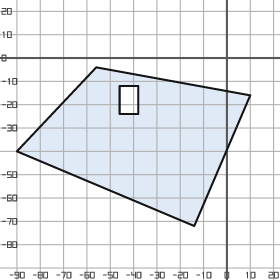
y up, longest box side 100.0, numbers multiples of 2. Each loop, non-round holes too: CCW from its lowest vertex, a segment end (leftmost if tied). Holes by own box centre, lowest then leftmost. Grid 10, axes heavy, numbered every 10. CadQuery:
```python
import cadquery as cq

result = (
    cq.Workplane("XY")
    .moveTo(-14.0, -72.0)
    .lineTo(10.0, -16.0)
    .lineTo(-56.0, -4.0)
    .lineTo(-90.0, -40.0)
    .close()
    .moveTo(-46.0, -24.0)
    .lineTo(-38.0, -24.0)
    .lineTo(-38.0, -12.0)
    .lineTo(-46.0, -12.0)
    .close()
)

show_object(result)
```